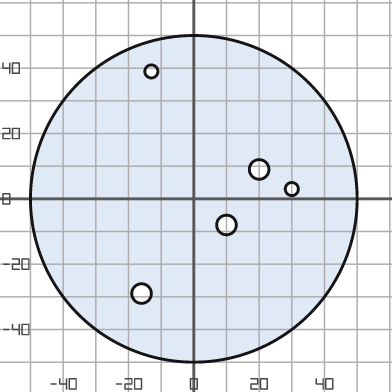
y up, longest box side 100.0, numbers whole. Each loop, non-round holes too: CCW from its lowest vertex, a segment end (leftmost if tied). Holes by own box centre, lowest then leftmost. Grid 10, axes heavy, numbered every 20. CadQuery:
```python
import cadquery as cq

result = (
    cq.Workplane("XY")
    .moveTo(0.0, 0.0)
    .circle(50.0)
    .moveTo(-16.0, -29.0)
    .circle(3.0)
    .moveTo(10.0, -8.0)
    .circle(3.0)
    .moveTo(30.0, 3.0)
    .circle(2.0)
    .moveTo(20.0, 9.0)
    .circle(3.0)
    .moveTo(-13.0, 39.0)
    .circle(2.0)
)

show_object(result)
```